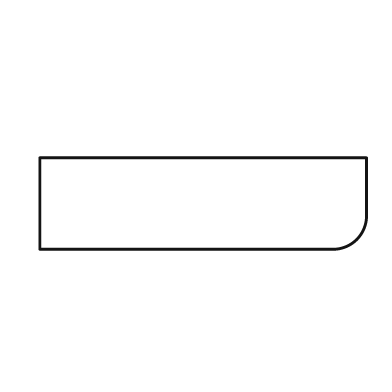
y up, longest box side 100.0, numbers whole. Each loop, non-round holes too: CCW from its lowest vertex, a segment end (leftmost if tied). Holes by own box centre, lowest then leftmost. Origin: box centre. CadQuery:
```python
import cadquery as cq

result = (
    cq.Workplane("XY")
    .moveTo(-50.0, -14.0)
    .lineTo(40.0, -14.0)
    .threePointArc((47.0, -11.0), (50.0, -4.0))
    .lineTo(50.0, 14.0)
    .lineTo(-50.0, 14.0)
    .close()
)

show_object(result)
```